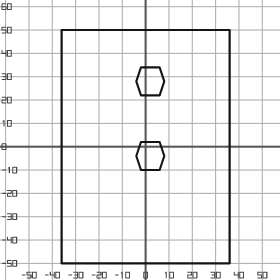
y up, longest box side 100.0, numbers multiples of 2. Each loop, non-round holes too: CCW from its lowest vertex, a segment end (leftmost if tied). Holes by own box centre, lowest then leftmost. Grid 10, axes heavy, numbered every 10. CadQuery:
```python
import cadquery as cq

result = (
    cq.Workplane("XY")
    .moveTo(-36.0, -50.0)
    .lineTo(36.0, -50.0)
    .lineTo(36.0, 50.0)
    .lineTo(-36.0, 50.0)
    .close()
    .moveTo(-2.0, -10.0)
    .lineTo(6.0, -10.0)
    .lineTo(8.0, -4.0)
    .lineTo(6.0, 2.0)
    .lineTo(-2.0, 2.0)
    .lineTo(-4.0, -4.0)
    .close()
    .moveTo(-2.0, 22.0)
    .lineTo(6.0, 22.0)
    .lineTo(8.0, 28.0)
    .lineTo(6.0, 34.0)
    .lineTo(-2.0, 34.0)
    .lineTo(-4.0, 28.0)
    .close()
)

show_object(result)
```